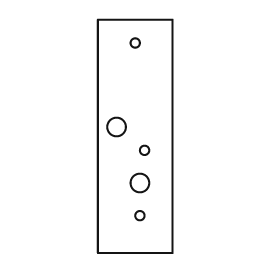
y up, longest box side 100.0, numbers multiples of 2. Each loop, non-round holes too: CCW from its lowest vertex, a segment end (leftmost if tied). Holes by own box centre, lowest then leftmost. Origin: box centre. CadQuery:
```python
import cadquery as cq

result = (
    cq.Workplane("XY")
    .moveTo(-16.0, -50.0)
    .lineTo(16.0, -50.0)
    .lineTo(16.0, 50.0)
    .lineTo(-16.0, 50.0)
    .close()
    .moveTo(2.0, -34.0)
    .circle(2.0)
    .moveTo(2.0, -20.0)
    .circle(4.0)
    .moveTo(4.0, -6.0)
    .circle(2.0)
    .moveTo(-8.0, 4.0)
    .circle(4.0)
    .moveTo(0.0, 40.0)
    .circle(2.0)
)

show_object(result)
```